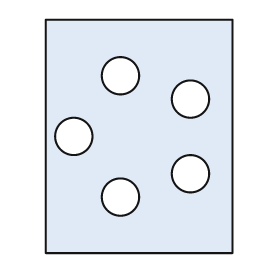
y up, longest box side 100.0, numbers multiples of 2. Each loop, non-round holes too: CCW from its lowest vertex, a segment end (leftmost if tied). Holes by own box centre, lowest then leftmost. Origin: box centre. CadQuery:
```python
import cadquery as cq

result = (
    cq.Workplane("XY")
    .moveTo(-40.0, -50.0)
    .lineTo(40.0, -50.0)
    .lineTo(40.0, 50.0)
    .lineTo(-40.0, 50.0)
    .close()
    .moveTo(-8.0, -26.0)
    .circle(8.0)
    .moveTo(22.0, -16.0)
    .circle(8.0)
    .moveTo(-28.0, 0.0)
    .circle(8.0)
    .moveTo(22.0, 16.0)
    .circle(8.0)
    .moveTo(-8.0, 26.0)
    .circle(8.0)
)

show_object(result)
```